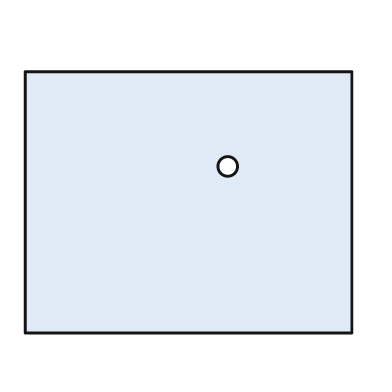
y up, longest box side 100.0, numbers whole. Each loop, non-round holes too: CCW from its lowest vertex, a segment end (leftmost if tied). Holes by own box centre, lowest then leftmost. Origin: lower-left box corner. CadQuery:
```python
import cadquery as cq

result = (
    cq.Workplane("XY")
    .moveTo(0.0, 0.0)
    .lineTo(100.0, 0.0)
    .lineTo(100.0, 80.0)
    .lineTo(0.0, 80.0)
    .close()
    .moveTo(62.0, 51.0)
    .circle(3.0)
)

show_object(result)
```